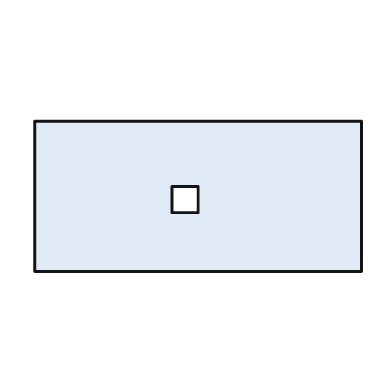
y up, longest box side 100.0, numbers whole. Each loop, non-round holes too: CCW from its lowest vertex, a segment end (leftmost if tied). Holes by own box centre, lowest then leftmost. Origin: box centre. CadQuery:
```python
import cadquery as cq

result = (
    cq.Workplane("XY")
    .moveTo(-50.0, -23.0)
    .lineTo(50.0, -23.0)
    .lineTo(50.0, 23.0)
    .lineTo(-50.0, 23.0)
    .close()
    .moveTo(-8.0, -5.0)
    .lineTo(0.0, -5.0)
    .lineTo(0.0, 3.0)
    .lineTo(-8.0, 3.0)
    .close()
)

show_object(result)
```